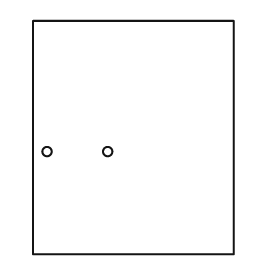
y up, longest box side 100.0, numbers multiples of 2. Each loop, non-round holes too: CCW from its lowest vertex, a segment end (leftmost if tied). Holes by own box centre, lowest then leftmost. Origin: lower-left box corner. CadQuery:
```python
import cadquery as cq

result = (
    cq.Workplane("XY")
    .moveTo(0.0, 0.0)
    .lineTo(86.0, 0.0)
    .lineTo(86.0, 100.0)
    .lineTo(0.0, 100.0)
    .close()
    .moveTo(6.0, 44.0)
    .circle(2.0)
    .moveTo(32.0, 44.0)
    .circle(2.0)
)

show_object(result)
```